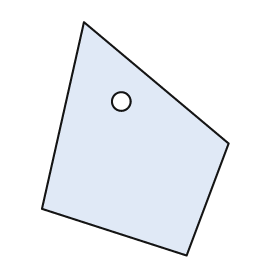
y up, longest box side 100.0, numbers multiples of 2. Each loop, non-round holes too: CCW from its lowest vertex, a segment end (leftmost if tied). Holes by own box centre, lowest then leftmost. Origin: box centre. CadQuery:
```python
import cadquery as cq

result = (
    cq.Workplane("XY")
    .moveTo(22.0, -50.0)
    .lineTo(40.0, -2.0)
    .lineTo(-22.0, 50.0)
    .lineTo(-40.0, -30.0)
    .close()
    .moveTo(-6.0, 16.0)
    .circle(4.0)
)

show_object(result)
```